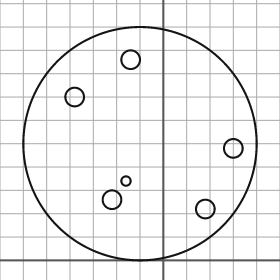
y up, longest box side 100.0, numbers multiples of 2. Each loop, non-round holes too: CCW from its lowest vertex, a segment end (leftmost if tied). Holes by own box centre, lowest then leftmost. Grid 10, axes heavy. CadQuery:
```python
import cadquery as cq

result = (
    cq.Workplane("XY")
    .moveTo(-10.0, 50.0)
    .circle(50.0)
    .moveTo(18.0, 22.0)
    .circle(4.0)
    .moveTo(-22.0, 26.0)
    .circle(4.0)
    .moveTo(-16.0, 34.0)
    .circle(2.0)
    .moveTo(30.0, 48.0)
    .circle(4.0)
    .moveTo(-38.0, 70.0)
    .circle(4.0)
    .moveTo(-14.0, 86.0)
    .circle(4.0)
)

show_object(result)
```